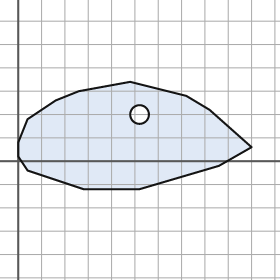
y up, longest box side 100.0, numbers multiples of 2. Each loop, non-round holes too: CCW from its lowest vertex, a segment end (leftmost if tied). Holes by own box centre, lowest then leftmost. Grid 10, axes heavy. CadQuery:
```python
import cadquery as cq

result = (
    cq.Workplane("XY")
    .moveTo(28.0, -12.0)
    .lineTo(52.0, -12.0)
    .lineTo(86.0, -2.0)
    .lineTo(100.0, 6.0)
    .lineTo(82.0, 22.0)
    .lineTo(72.0, 28.0)
    .lineTo(48.0, 34.0)
    .lineTo(26.0, 30.0)
    .lineTo(16.0, 26.0)
    .lineTo(4.0, 18.0)
    .lineTo(0.0, 8.0)
    .lineTo(0.0, 2.0)
    .lineTo(4.0, -4.0)
    .close()
    .moveTo(52.0, 20.0)
    .circle(4.0)
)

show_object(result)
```